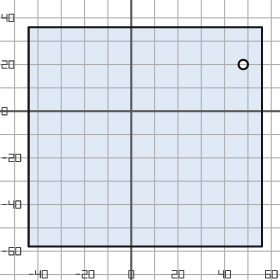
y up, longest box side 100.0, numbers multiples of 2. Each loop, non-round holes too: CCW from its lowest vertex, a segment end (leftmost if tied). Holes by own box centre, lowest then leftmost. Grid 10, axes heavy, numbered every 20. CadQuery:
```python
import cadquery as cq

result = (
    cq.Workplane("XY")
    .moveTo(-44.0, -58.0)
    .lineTo(56.0, -58.0)
    .lineTo(56.0, 36.0)
    .lineTo(-44.0, 36.0)
    .close()
    .moveTo(48.0, 20.0)
    .circle(2.0)
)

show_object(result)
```